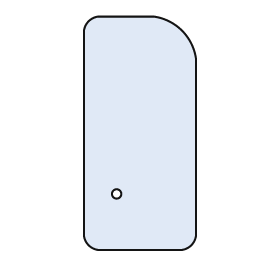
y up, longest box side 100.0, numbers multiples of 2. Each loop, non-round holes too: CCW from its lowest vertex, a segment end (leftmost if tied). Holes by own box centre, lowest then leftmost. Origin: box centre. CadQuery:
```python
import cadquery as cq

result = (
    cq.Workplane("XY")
    .moveTo(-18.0, -50.0)
    .lineTo(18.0, -50.0)
    .threePointArc((22.0, -48.0), (24.0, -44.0))
    .lineTo(24.0, 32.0)
    .threePointArc((18.0, 44.0), (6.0, 50.0))
    .lineTo(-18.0, 50.0)
    .threePointArc((-22.0, 48.0), (-24.0, 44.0))
    .lineTo(-24.0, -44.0)
    .threePointArc((-22.0, -48.0), (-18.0, -50.0))
    .close()
    .moveTo(-10.0, -26.0)
    .circle(2.0)
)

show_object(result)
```